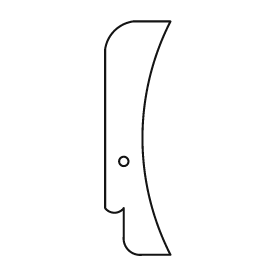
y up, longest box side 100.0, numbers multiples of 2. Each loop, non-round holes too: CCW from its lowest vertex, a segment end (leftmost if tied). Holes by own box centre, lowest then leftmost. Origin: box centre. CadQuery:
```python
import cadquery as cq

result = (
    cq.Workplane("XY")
    .moveTo(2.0, -50.0)
    .lineTo(14.0, -50.0)
    .threePointArc((2.0, 0.0), (14.0, 50.0))
    .lineTo(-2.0, 50.0)
    .threePointArc((-10.0, 46.0), (-14.0, 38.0))
    .lineTo(-14.0, -30.0)
    .threePointArc((-10.0, -32.0), (-6.0, -30.0))
    .lineTo(-6.0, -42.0)
    .threePointArc((-4.0, -48.0), (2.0, -50.0))
    .close()
    .moveTo(-6.0, -10.0)
    .circle(2.0)
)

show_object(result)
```